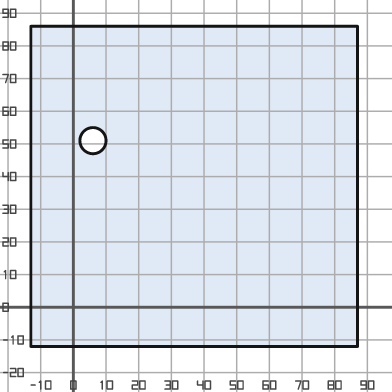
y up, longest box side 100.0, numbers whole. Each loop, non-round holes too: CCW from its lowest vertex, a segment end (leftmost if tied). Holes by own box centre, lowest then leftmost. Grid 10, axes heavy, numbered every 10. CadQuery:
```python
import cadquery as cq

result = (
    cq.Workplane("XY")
    .moveTo(-13.0, -12.0)
    .lineTo(87.0, -12.0)
    .lineTo(87.0, 86.0)
    .lineTo(-13.0, 86.0)
    .close()
    .moveTo(6.0, 51.0)
    .circle(4.0)
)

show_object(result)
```